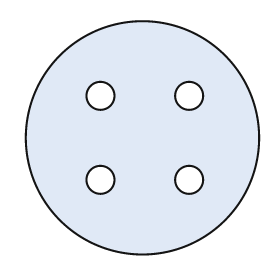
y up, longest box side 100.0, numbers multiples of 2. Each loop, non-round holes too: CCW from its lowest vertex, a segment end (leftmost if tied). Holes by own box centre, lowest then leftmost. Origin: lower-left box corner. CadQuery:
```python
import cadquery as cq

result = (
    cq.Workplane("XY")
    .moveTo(50.0, 50.0)
    .circle(50.0)
    .moveTo(32.0, 32.0)
    .circle(6.0)
    .moveTo(70.0, 32.0)
    .circle(6.0)
    .moveTo(32.0, 68.0)
    .circle(6.0)
    .moveTo(70.0, 68.0)
    .circle(6.0)
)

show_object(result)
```